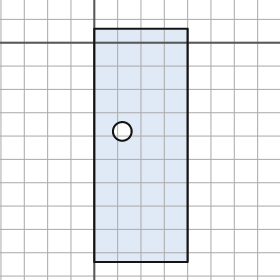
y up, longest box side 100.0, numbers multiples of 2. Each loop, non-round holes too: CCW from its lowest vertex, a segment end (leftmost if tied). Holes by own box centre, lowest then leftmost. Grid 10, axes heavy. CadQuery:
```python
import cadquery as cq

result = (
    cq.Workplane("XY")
    .moveTo(0.0, -94.0)
    .lineTo(40.0, -94.0)
    .lineTo(40.0, 6.0)
    .lineTo(0.0, 6.0)
    .close()
    .moveTo(12.0, -38.0)
    .circle(4.0)
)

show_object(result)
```